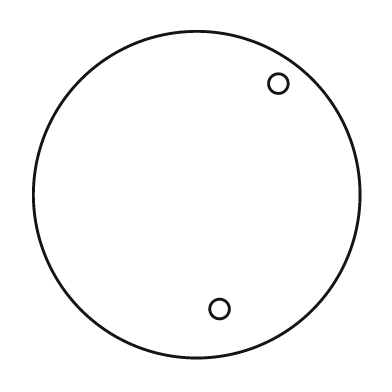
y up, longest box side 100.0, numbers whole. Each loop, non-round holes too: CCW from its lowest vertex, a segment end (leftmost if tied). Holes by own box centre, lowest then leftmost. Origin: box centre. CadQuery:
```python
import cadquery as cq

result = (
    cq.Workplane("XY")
    .moveTo(0.0, 0.0)
    .circle(50.0)
    .moveTo(7.0, -35.0)
    .circle(3.0)
    .moveTo(25.0, 34.0)
    .circle(3.0)
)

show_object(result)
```